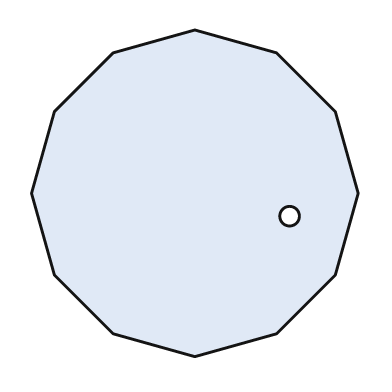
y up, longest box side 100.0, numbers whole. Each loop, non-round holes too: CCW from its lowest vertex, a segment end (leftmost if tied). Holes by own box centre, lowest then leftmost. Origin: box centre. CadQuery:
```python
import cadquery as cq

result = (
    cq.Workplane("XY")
    .moveTo(0.0, -50.0)
    .lineTo(25.0, -43.0)
    .lineTo(43.0, -25.0)
    .lineTo(50.0, 0.0)
    .lineTo(43.0, 25.0)
    .lineTo(25.0, 43.0)
    .lineTo(0.0, 50.0)
    .lineTo(-25.0, 43.0)
    .lineTo(-43.0, 25.0)
    .lineTo(-50.0, 0.0)
    .lineTo(-43.0, -25.0)
    .lineTo(-25.0, -43.0)
    .close()
    .moveTo(29.0, -7.0)
    .circle(3.0)
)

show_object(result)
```